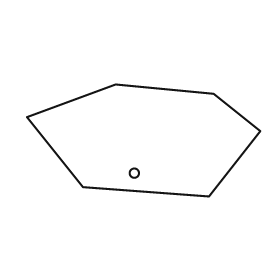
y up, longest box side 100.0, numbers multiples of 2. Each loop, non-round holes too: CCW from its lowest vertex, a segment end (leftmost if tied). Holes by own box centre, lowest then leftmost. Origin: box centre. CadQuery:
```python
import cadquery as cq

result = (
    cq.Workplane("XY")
    .moveTo(28.0, -24.0)
    .lineTo(50.0, 4.0)
    .lineTo(30.0, 20.0)
    .lineTo(-12.0, 24.0)
    .lineTo(-50.0, 10.0)
    .lineTo(-26.0, -20.0)
    .close()
    .moveTo(-4.0, -14.0)
    .circle(2.0)
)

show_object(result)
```